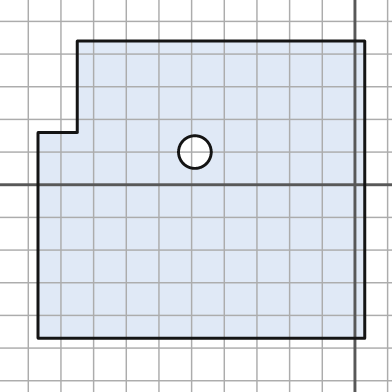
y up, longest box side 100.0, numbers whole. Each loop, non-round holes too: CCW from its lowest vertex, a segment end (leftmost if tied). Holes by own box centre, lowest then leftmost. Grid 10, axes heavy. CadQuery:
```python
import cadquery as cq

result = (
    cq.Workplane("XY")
    .moveTo(-97.0, -47.0)
    .lineTo(3.0, -47.0)
    .lineTo(3.0, 44.0)
    .lineTo(-85.0, 44.0)
    .lineTo(-85.0, 16.0)
    .lineTo(-97.0, 16.0)
    .close()
    .moveTo(-49.0, 10.0)
    .circle(5.0)
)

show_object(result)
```